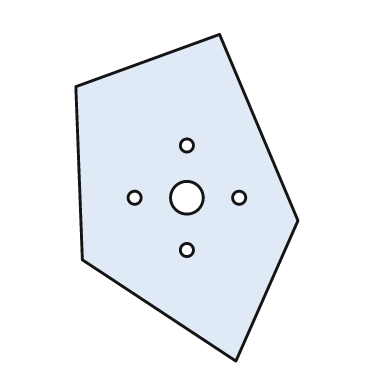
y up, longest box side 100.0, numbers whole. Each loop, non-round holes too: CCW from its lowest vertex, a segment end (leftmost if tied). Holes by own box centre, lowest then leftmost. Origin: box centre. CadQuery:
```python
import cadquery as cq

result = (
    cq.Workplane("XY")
    .moveTo(15.0, -50.0)
    .lineTo(34.0, -7.0)
    .lineTo(10.0, 50.0)
    .lineTo(-34.0, 34.0)
    .lineTo(-32.0, -19.0)
    .close()
    .moveTo(0.0, -16.0)
    .circle(2.0)
    .moveTo(-16.0, 0.0)
    .circle(2.0)
    .moveTo(0.0, 0.0)
    .circle(5.0)
    .moveTo(16.0, 0.0)
    .circle(2.0)
    .moveTo(0.0, 16.0)
    .circle(2.0)
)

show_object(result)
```